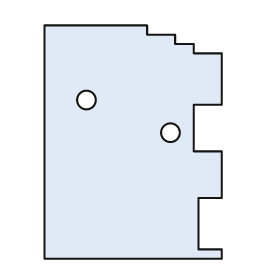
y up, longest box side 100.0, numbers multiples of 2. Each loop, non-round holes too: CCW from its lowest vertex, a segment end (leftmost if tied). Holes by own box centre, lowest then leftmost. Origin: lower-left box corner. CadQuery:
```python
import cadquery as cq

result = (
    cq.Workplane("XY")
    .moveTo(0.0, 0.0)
    .lineTo(76.0, 0.0)
    .lineTo(76.0, 4.0)
    .lineTo(66.0, 4.0)
    .lineTo(66.0, 26.0)
    .lineTo(76.0, 26.0)
    .lineTo(76.0, 46.0)
    .lineTo(64.0, 46.0)
    .lineTo(64.0, 66.0)
    .lineTo(76.0, 66.0)
    .lineTo(76.0, 88.0)
    .lineTo(64.0, 88.0)
    .lineTo(64.0, 92.0)
    .lineTo(56.0, 92.0)
    .lineTo(56.0, 96.0)
    .lineTo(44.0, 96.0)
    .lineTo(44.0, 100.0)
    .lineTo(0.0, 100.0)
    .close()
    .moveTo(54.0, 54.0)
    .circle(4.0)
    .moveTo(18.0, 68.0)
    .circle(4.0)
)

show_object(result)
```